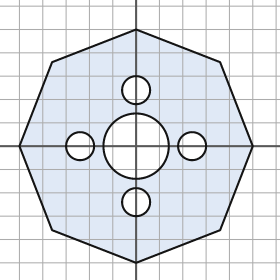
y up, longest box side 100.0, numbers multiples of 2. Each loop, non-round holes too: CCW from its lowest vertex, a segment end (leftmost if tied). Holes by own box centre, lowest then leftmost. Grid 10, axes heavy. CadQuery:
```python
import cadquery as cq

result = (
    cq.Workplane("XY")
    .moveTo(0.0, -50.0)
    .lineTo(36.0, -36.0)
    .lineTo(50.0, 0.0)
    .lineTo(36.0, 36.0)
    .lineTo(0.0, 50.0)
    .lineTo(-36.0, 36.0)
    .lineTo(-50.0, 0.0)
    .lineTo(-36.0, -36.0)
    .close()
    .moveTo(0.0, -24.0)
    .circle(6.0)
    .moveTo(-24.0, 0.0)
    .circle(6.0)
    .moveTo(0.0, 0.0)
    .circle(14.0)
    .moveTo(24.0, 0.0)
    .circle(6.0)
    .moveTo(0.0, 24.0)
    .circle(6.0)
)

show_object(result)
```